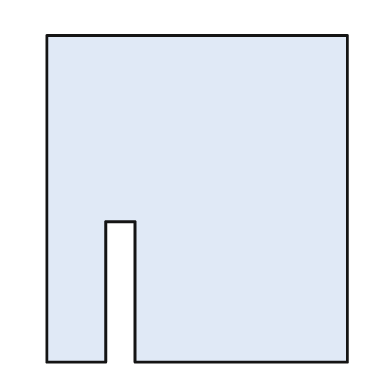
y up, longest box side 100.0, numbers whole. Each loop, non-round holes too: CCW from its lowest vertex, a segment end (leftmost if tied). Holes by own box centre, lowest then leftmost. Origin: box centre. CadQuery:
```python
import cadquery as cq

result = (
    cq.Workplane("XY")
    .moveTo(-46.0, -50.0)
    .lineTo(-28.0, -50.0)
    .lineTo(-28.0, -7.0)
    .lineTo(-19.0, -7.0)
    .lineTo(-19.0, -50.0)
    .lineTo(46.0, -50.0)
    .lineTo(46.0, 50.0)
    .lineTo(-46.0, 50.0)
    .close()
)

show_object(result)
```